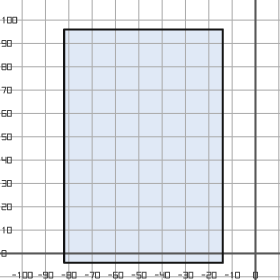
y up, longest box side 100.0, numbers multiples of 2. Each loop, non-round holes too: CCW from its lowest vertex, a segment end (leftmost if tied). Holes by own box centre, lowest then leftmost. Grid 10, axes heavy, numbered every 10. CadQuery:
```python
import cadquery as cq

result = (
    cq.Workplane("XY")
    .moveTo(-82.0, -4.0)
    .lineTo(-14.0, -4.0)
    .lineTo(-14.0, 96.0)
    .lineTo(-82.0, 96.0)
    .close()
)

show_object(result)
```